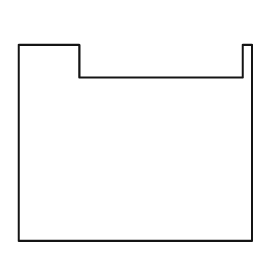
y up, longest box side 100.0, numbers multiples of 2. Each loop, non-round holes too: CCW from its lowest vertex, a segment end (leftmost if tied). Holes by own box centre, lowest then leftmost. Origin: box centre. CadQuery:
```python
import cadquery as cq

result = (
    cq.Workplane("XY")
    .moveTo(-50.0, -42.0)
    .lineTo(50.0, -42.0)
    .lineTo(50.0, 42.0)
    .lineTo(46.0, 42.0)
    .lineTo(46.0, 28.0)
    .lineTo(-24.0, 28.0)
    .lineTo(-24.0, 42.0)
    .lineTo(-50.0, 42.0)
    .close()
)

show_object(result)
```